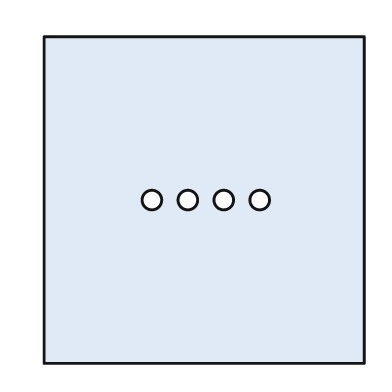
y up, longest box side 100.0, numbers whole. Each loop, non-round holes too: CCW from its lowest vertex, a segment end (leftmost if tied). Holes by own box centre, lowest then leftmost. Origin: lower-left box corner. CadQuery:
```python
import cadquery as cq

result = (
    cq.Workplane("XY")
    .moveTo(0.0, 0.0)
    .lineTo(98.0, 0.0)
    .lineTo(98.0, 100.0)
    .lineTo(0.0, 100.0)
    .close()
    .moveTo(33.0, 50.0)
    .circle(3.0)
    .moveTo(44.0, 50.0)
    .circle(3.0)
    .moveTo(55.0, 50.0)
    .circle(3.0)
    .moveTo(66.0, 50.0)
    .circle(3.0)
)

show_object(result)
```